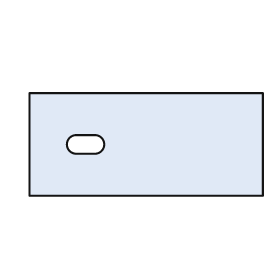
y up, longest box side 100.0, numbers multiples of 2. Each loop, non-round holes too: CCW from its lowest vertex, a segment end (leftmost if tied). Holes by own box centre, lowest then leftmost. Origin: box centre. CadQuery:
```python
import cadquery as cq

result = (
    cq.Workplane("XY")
    .moveTo(-50.0, -22.0)
    .lineTo(50.0, -22.0)
    .lineTo(50.0, 22.0)
    .lineTo(-50.0, 22.0)
    .close()
    .moveTo(-30.0, -4.0)
    .lineTo(-22.0, -4.0)
    .threePointArc((-18.0, 0.0), (-22.0, 4.0))
    .lineTo(-30.0, 4.0)
    .threePointArc((-34.0, 0.0), (-30.0, -4.0))
    .close()
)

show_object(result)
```